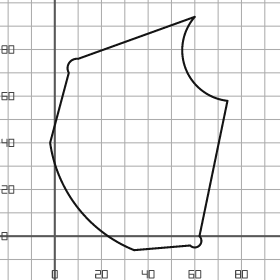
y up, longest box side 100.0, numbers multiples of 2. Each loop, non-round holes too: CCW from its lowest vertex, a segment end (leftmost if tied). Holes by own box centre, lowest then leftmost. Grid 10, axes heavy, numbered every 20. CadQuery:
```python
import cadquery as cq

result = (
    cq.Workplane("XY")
    .moveTo(34.0, -6.0)
    .lineTo(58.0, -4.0)
    .threePointArc((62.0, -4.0), (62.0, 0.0))
    .lineTo(74.0, 58.0)
    .threePointArc((56.0, 72.0), (60.0, 94.0))
    .lineTo(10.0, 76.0)
    .threePointArc((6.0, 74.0), (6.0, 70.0))
    .lineTo(-2.0, 40.0)
    .threePointArc((10.0, 12.0), (34.0, -6.0))
    .close()
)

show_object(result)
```